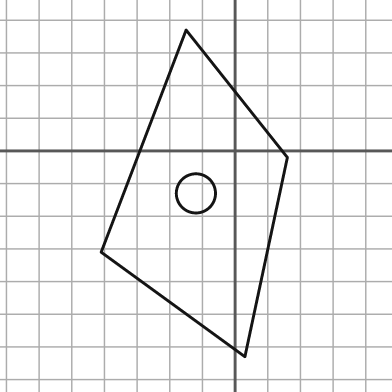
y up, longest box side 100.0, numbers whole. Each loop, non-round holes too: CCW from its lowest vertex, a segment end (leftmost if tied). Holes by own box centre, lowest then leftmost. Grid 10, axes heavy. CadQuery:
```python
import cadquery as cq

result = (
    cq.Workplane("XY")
    .moveTo(3.0, -63.0)
    .lineTo(16.0, -2.0)
    .lineTo(-15.0, 37.0)
    .lineTo(-41.0, -31.0)
    .close()
    .moveTo(-12.0, -13.0)
    .circle(6.0)
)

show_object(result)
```